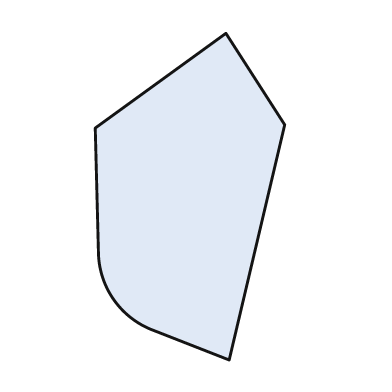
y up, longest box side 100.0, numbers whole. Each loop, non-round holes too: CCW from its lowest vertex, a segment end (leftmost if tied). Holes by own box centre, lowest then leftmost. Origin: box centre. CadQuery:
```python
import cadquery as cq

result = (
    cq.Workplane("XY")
    .moveTo(12.0, -50.0)
    .lineTo(29.0, 22.0)
    .lineTo(11.0, 50.0)
    .lineTo(-29.0, 21.0)
    .lineTo(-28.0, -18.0)
    .threePointArc((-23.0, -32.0), (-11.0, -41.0))
    .close()
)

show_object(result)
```